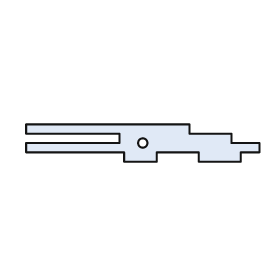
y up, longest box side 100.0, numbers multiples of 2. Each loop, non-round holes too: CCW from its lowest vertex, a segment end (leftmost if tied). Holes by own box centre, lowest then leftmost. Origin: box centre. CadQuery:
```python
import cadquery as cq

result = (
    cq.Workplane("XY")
    .moveTo(-8.0, -8.0)
    .lineTo(6.0, -8.0)
    .lineTo(6.0, -4.0)
    .lineTo(24.0, -4.0)
    .lineTo(24.0, -8.0)
    .lineTo(42.0, -8.0)
    .lineTo(42.0, -4.0)
    .lineTo(50.0, -4.0)
    .lineTo(50.0, 0.0)
    .lineTo(38.0, 0.0)
    .lineTo(38.0, 4.0)
    .lineTo(20.0, 4.0)
    .lineTo(20.0, 8.0)
    .lineTo(-50.0, 8.0)
    .lineTo(-50.0, 4.0)
    .lineTo(-10.0, 4.0)
    .lineTo(-10.0, 0.0)
    .lineTo(-50.0, 0.0)
    .lineTo(-50.0, -4.0)
    .lineTo(-8.0, -4.0)
    .close()
    .moveTo(0.0, 0.0)
    .circle(2.0)
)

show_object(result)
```